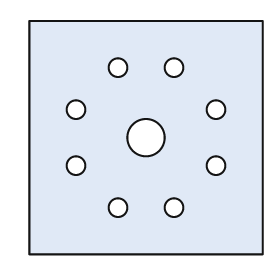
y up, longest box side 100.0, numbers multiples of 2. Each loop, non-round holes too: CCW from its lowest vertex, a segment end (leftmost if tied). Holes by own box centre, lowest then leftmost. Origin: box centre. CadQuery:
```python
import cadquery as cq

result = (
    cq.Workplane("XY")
    .moveTo(-50.0, -50.0)
    .lineTo(50.0, -50.0)
    .lineTo(50.0, 50.0)
    .lineTo(-50.0, 50.0)
    .close()
    .moveTo(-12.0, -30.0)
    .circle(4.0)
    .moveTo(12.0, -30.0)
    .circle(4.0)
    .moveTo(-30.0, -12.0)
    .circle(4.0)
    .moveTo(30.0, -12.0)
    .circle(4.0)
    .moveTo(0.0, 0.0)
    .circle(8.0)
    .moveTo(-30.0, 12.0)
    .circle(4.0)
    .moveTo(30.0, 12.0)
    .circle(4.0)
    .moveTo(-12.0, 30.0)
    .circle(4.0)
    .moveTo(12.0, 30.0)
    .circle(4.0)
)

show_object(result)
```